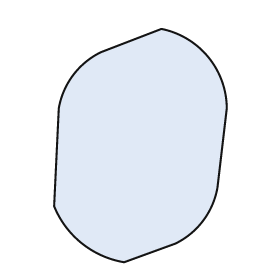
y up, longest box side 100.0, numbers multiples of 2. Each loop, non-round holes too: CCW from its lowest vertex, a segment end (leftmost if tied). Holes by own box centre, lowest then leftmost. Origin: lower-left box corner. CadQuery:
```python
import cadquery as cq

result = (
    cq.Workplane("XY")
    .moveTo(30.0, 0.0)
    .lineTo(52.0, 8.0)
    .threePointArc((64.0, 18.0), (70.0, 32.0))
    .lineTo(74.0, 66.0)
    .threePointArc((66.0, 88.0), (46.0, 100.0))
    .lineTo(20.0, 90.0)
    .threePointArc((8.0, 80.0), (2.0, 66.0))
    .lineTo(0.0, 24.0)
    .threePointArc((12.0, 8.0), (30.0, 0.0))
    .close()
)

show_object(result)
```